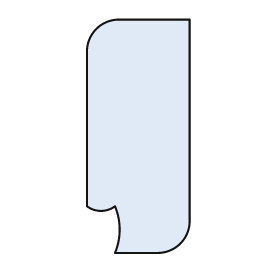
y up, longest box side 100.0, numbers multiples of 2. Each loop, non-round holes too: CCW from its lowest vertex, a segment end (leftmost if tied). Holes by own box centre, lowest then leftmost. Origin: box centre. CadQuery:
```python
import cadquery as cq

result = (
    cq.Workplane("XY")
    .moveTo(-10.0, -50.0)
    .lineTo(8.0, -50.0)
    .threePointArc((18.0, -46.0), (22.0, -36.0))
    .lineTo(22.0, 50.0)
    .lineTo(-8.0, 50.0)
    .threePointArc((-18.0, 46.0), (-22.0, 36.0))
    .lineTo(-22.0, -30.0)
    .threePointArc((-16.0, -32.0), (-10.0, -30.0))
    .threePointArc((-8.0, -40.0), (-10.0, -50.0))
    .close()
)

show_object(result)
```